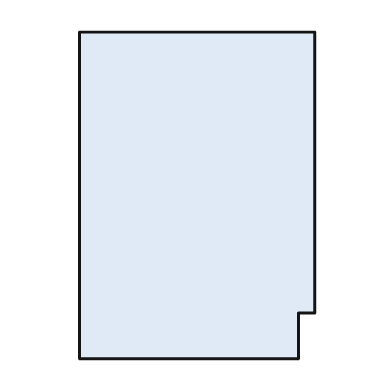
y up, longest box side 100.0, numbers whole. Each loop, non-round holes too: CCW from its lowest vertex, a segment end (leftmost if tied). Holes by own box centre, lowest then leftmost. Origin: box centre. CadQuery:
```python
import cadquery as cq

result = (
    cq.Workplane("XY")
    .moveTo(-36.0, -50.0)
    .lineTo(31.0, -50.0)
    .lineTo(31.0, -36.0)
    .lineTo(36.0, -36.0)
    .lineTo(36.0, 50.0)
    .lineTo(-36.0, 50.0)
    .close()
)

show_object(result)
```